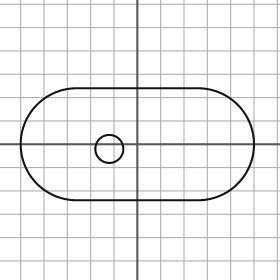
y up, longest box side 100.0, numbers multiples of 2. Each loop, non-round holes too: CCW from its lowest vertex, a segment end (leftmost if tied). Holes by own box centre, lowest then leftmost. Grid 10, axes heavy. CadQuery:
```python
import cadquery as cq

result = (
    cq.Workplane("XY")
    .moveTo(-26.0, -24.0)
    .lineTo(26.0, -24.0)
    .threePointArc((50.0, 0.0), (26.0, 24.0))
    .lineTo(-26.0, 24.0)
    .threePointArc((-50.0, 0.0), (-26.0, -24.0))
    .close()
    .moveTo(-12.0, -2.0)
    .circle(6.0)
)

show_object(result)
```